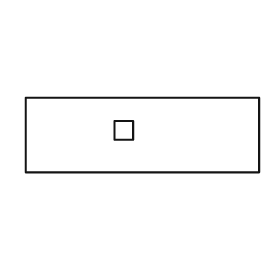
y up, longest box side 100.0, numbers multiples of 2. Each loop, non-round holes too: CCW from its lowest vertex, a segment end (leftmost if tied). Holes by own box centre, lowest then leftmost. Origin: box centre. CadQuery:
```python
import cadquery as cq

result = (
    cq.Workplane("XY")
    .moveTo(-50.0, -16.0)
    .lineTo(50.0, -16.0)
    .lineTo(50.0, 16.0)
    .lineTo(-50.0, 16.0)
    .close()
    .moveTo(-12.0, -2.0)
    .lineTo(-4.0, -2.0)
    .lineTo(-4.0, 6.0)
    .lineTo(-12.0, 6.0)
    .close()
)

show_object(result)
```